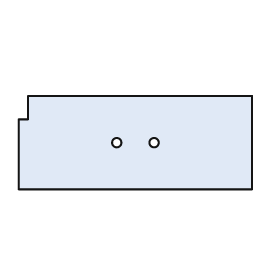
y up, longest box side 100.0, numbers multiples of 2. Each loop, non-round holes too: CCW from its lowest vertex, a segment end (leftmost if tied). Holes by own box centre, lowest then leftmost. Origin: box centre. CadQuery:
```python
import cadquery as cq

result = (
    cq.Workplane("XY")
    .moveTo(-50.0, -20.0)
    .lineTo(50.0, -20.0)
    .lineTo(50.0, 20.0)
    .lineTo(-46.0, 20.0)
    .lineTo(-46.0, 10.0)
    .lineTo(-50.0, 10.0)
    .close()
    .moveTo(-8.0, 0.0)
    .circle(2.0)
    .moveTo(8.0, 0.0)
    .circle(2.0)
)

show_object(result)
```